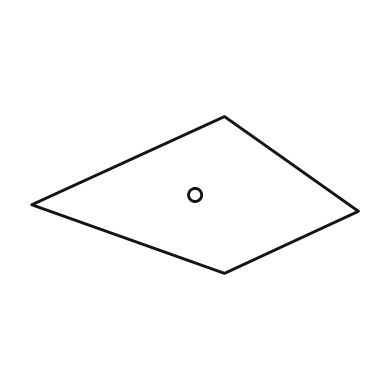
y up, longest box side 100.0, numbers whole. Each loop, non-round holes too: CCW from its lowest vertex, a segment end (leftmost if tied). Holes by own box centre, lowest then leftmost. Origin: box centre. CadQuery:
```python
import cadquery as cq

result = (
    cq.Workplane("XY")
    .moveTo(9.0, -24.0)
    .lineTo(50.0, -5.0)
    .lineTo(9.0, 24.0)
    .lineTo(-50.0, -3.0)
    .close()
    .moveTo(0.0, 0.0)
    .circle(2.0)
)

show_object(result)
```